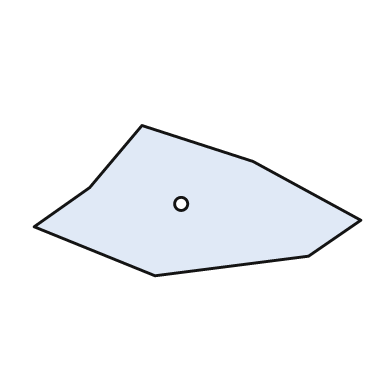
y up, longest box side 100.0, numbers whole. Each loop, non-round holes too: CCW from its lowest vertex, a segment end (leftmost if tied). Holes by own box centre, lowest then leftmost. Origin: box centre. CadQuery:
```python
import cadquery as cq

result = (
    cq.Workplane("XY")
    .moveTo(-13.0, -23.0)
    .lineTo(34.0, -17.0)
    .lineTo(50.0, -6.0)
    .lineTo(17.0, 12.0)
    .lineTo(-17.0, 23.0)
    .lineTo(-33.0, 4.0)
    .lineTo(-50.0, -8.0)
    .close()
    .moveTo(-5.0, -1.0)
    .circle(2.0)
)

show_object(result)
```